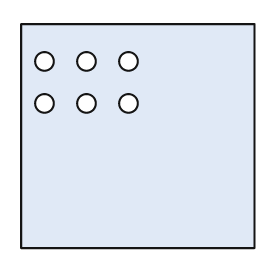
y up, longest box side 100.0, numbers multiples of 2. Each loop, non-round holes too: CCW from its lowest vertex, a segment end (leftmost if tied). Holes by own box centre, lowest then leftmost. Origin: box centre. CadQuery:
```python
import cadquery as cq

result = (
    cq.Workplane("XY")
    .moveTo(-50.0, -48.0)
    .lineTo(50.0, -48.0)
    .lineTo(50.0, 48.0)
    .lineTo(-50.0, 48.0)
    .close()
    .moveTo(-40.0, 14.0)
    .circle(4.0)
    .moveTo(-22.0, 14.0)
    .circle(4.0)
    .moveTo(-4.0, 14.0)
    .circle(4.0)
    .moveTo(-40.0, 32.0)
    .circle(4.0)
    .moveTo(-22.0, 32.0)
    .circle(4.0)
    .moveTo(-4.0, 32.0)
    .circle(4.0)
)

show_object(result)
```